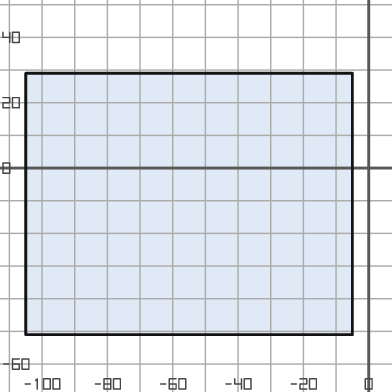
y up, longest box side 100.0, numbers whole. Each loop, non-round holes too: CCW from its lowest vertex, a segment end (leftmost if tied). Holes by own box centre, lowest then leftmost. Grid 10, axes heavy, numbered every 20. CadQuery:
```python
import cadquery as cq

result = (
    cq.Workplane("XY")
    .moveTo(-105.0, -51.0)
    .lineTo(-5.0, -51.0)
    .lineTo(-5.0, 29.0)
    .lineTo(-105.0, 29.0)
    .close()
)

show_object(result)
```